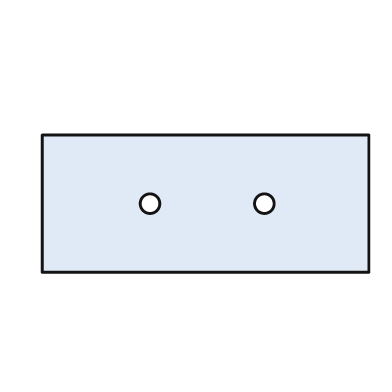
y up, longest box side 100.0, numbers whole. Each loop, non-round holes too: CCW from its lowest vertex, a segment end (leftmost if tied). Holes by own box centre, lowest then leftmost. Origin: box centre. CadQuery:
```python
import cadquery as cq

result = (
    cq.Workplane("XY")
    .moveTo(-50.0, -21.0)
    .lineTo(50.0, -21.0)
    .lineTo(50.0, 21.0)
    .lineTo(-50.0, 21.0)
    .close()
    .moveTo(-17.0, 0.0)
    .circle(3.0)
    .moveTo(18.0, 0.0)
    .circle(3.0)
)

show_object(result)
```